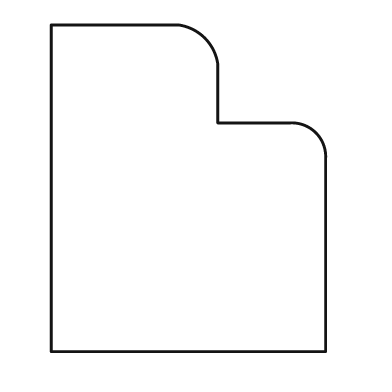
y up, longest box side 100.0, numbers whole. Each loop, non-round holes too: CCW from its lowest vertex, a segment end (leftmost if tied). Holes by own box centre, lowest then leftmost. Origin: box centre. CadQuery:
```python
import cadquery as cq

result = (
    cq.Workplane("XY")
    .moveTo(-42.0, -50.0)
    .lineTo(42.0, -50.0)
    .lineTo(42.0, 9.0)
    .threePointArc((39.0, 17.0), (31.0, 20.0))
    .lineTo(9.0, 20.0)
    .lineTo(9.0, 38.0)
    .threePointArc((5.0, 46.0), (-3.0, 50.0))
    .lineTo(-42.0, 50.0)
    .close()
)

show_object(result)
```